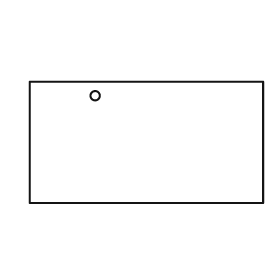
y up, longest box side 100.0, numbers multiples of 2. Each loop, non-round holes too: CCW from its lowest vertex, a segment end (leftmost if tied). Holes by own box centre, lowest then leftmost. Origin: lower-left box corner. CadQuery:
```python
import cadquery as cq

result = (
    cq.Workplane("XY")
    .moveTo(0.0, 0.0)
    .lineTo(100.0, 0.0)
    .lineTo(100.0, 52.0)
    .lineTo(0.0, 52.0)
    .close()
    .moveTo(28.0, 46.0)
    .circle(2.0)
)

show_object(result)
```